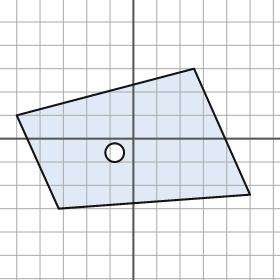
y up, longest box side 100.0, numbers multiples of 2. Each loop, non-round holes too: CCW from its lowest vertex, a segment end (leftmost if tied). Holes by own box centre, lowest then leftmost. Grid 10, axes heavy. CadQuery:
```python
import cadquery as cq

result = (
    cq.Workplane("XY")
    .moveTo(-32.0, -30.0)
    .lineTo(50.0, -24.0)
    .lineTo(26.0, 30.0)
    .lineTo(-50.0, 10.0)
    .close()
    .moveTo(-8.0, -6.0)
    .circle(4.0)
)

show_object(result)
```